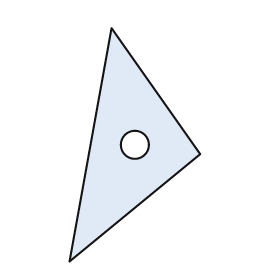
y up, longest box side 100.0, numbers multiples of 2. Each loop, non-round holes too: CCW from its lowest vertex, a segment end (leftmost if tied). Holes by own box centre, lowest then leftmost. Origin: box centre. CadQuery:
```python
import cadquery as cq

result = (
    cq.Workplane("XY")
    .moveTo(-28.0, -50.0)
    .lineTo(28.0, -4.0)
    .lineTo(-10.0, 50.0)
    .close()
    .moveTo(0.0, 0.0)
    .circle(6.0)
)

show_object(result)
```